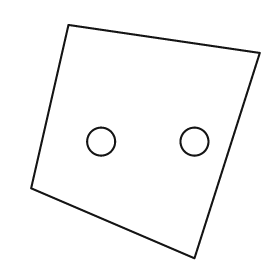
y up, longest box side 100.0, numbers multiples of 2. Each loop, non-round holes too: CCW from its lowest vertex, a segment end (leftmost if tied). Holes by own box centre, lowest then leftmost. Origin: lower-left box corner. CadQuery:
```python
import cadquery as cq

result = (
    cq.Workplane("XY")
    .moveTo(70.0, 0.0)
    .lineTo(98.0, 88.0)
    .lineTo(16.0, 100.0)
    .lineTo(0.0, 30.0)
    .close()
    .moveTo(30.0, 50.0)
    .circle(6.0)
    .moveTo(70.0, 50.0)
    .circle(6.0)
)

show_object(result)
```